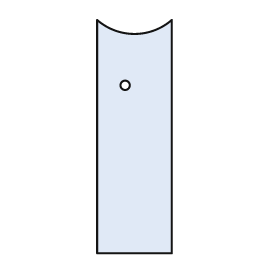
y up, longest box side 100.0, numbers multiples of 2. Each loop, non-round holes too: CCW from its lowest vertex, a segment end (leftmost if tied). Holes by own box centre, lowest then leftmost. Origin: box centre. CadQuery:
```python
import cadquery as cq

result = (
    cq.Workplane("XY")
    .moveTo(-16.0, -50.0)
    .lineTo(16.0, -50.0)
    .lineTo(16.0, 50.0)
    .threePointArc((0.0, 44.0), (-16.0, 50.0))
    .close()
    .moveTo(-4.0, 22.0)
    .circle(2.0)
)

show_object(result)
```